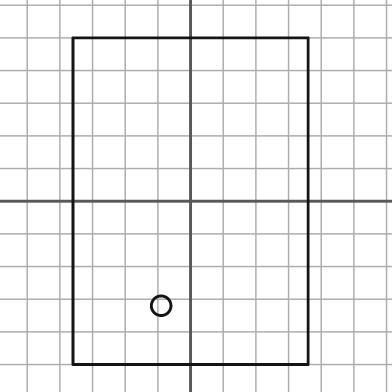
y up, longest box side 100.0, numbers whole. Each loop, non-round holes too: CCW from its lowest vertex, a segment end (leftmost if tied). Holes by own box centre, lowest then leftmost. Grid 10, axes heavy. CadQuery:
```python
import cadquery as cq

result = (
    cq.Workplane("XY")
    .moveTo(-36.0, -50.0)
    .lineTo(36.0, -50.0)
    .lineTo(36.0, 50.0)
    .lineTo(-36.0, 50.0)
    .close()
    .moveTo(-9.0, -32.0)
    .circle(3.0)
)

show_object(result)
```